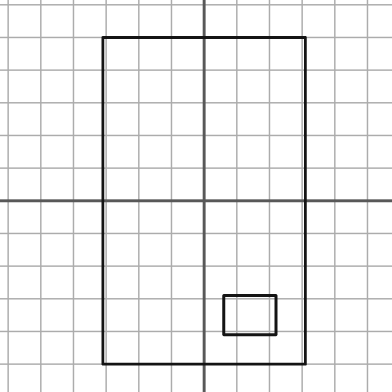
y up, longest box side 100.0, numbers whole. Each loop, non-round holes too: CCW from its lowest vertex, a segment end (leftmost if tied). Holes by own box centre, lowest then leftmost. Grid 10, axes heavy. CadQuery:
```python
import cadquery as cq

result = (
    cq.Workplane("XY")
    .moveTo(-31.0, -50.0)
    .lineTo(31.0, -50.0)
    .lineTo(31.0, 50.0)
    .lineTo(-31.0, 50.0)
    .close()
    .moveTo(6.0, -41.0)
    .lineTo(22.0, -41.0)
    .lineTo(22.0, -29.0)
    .lineTo(6.0, -29.0)
    .close()
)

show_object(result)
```